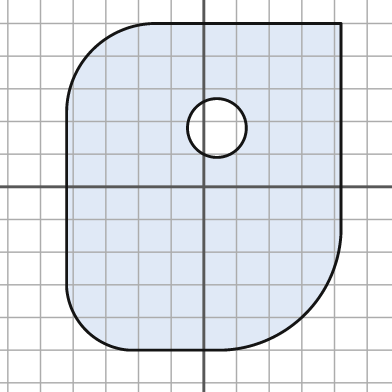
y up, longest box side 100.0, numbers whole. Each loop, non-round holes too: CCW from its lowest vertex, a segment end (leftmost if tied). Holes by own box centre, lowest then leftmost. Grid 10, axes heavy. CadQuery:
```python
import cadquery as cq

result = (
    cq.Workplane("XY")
    .moveTo(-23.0, -50.0)
    .lineTo(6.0, -50.0)
    .threePointArc((31.0, -39.0), (42.0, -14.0))
    .lineTo(42.0, 50.0)
    .lineTo(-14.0, 50.0)
    .threePointArc((-34.0, 42.0), (-42.0, 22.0))
    .lineTo(-42.0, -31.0)
    .threePointArc((-36.0, -44.0), (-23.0, -50.0))
    .close()
    .moveTo(4.0, 18.0)
    .circle(9.0)
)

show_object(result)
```